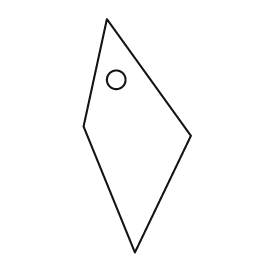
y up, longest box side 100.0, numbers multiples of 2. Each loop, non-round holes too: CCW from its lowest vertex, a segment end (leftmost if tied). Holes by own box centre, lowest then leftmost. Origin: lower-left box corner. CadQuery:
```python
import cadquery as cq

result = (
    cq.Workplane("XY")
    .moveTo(22.0, 0.0)
    .lineTo(46.0, 50.0)
    .lineTo(10.0, 100.0)
    .lineTo(0.0, 54.0)
    .close()
    .moveTo(14.0, 74.0)
    .circle(4.0)
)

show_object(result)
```